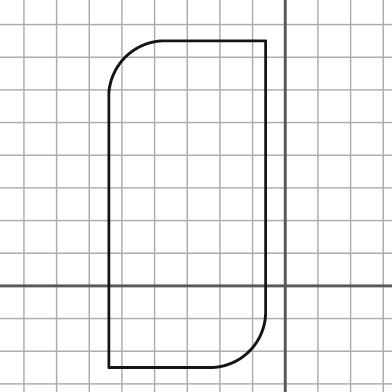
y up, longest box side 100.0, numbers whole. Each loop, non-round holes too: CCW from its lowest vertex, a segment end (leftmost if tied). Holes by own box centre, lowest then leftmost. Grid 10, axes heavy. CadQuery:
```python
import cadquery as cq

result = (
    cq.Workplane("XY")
    .moveTo(-54.0, -25.0)
    .lineTo(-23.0, -25.0)
    .threePointArc((-11.0, -20.0), (-6.0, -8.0))
    .lineTo(-6.0, 75.0)
    .lineTo(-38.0, 75.0)
    .threePointArc((-49.0, 70.0), (-54.0, 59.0))
    .close()
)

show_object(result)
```